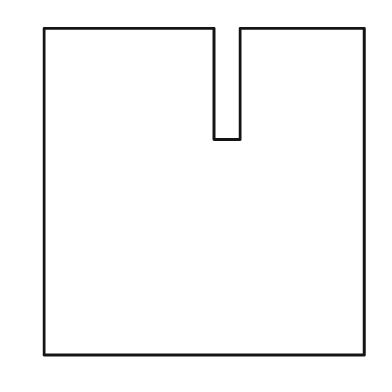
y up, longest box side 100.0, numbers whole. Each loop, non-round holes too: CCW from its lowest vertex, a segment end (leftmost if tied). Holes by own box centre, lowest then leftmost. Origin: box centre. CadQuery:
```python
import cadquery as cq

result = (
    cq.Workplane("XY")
    .moveTo(-49.0, -50.0)
    .lineTo(49.0, -50.0)
    .lineTo(49.0, 50.0)
    .lineTo(11.0, 50.0)
    .lineTo(11.0, 16.0)
    .lineTo(3.0, 16.0)
    .lineTo(3.0, 50.0)
    .lineTo(-49.0, 50.0)
    .close()
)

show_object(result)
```